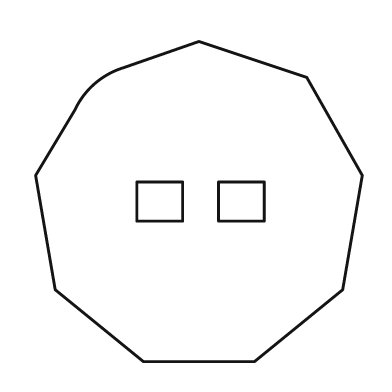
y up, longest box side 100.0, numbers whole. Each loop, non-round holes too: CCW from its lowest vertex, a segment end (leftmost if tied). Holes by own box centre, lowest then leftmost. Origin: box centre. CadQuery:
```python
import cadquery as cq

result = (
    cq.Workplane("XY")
    .moveTo(-17.0, -49.0)
    .lineTo(17.0, -49.0)
    .lineTo(44.0, -27.0)
    .lineTo(50.0, 8.0)
    .lineTo(33.0, 38.0)
    .lineTo(0.0, 49.0)
    .lineTo(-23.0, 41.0)
    .threePointArc((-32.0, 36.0), (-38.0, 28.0))
    .lineTo(-50.0, 8.0)
    .lineTo(-44.0, -27.0)
    .close()
    .moveTo(-19.0, -6.0)
    .lineTo(-5.0, -6.0)
    .lineTo(-5.0, 6.0)
    .lineTo(-19.0, 6.0)
    .close()
    .moveTo(6.0, -6.0)
    .lineTo(20.0, -6.0)
    .lineTo(20.0, 6.0)
    .lineTo(6.0, 6.0)
    .close()
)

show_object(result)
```